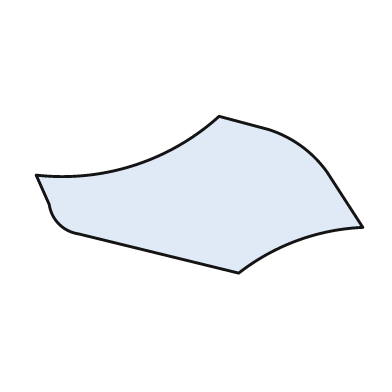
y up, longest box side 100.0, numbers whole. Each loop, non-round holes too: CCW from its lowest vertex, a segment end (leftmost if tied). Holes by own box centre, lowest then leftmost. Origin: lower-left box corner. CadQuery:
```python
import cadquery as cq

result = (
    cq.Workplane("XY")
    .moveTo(62.0, 0.0)
    .threePointArc((80.0, 10.0), (100.0, 14.0))
    .lineTo(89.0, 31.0)
    .threePointArc((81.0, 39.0), (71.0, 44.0))
    .lineTo(56.0, 48.0)
    .threePointArc((30.0, 33.0), (0.0, 30.0))
    .lineTo(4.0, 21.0)
    .threePointArc((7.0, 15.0), (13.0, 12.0))
    .close()
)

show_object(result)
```